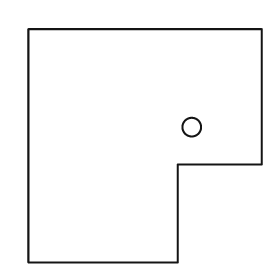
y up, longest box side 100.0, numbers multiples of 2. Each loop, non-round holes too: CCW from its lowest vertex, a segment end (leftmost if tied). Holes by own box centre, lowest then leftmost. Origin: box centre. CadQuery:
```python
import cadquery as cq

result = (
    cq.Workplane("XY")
    .moveTo(-50.0, -50.0)
    .lineTo(14.0, -50.0)
    .lineTo(14.0, -8.0)
    .lineTo(50.0, -8.0)
    .lineTo(50.0, 50.0)
    .lineTo(-50.0, 50.0)
    .close()
    .moveTo(20.0, 8.0)
    .circle(4.0)
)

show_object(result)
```